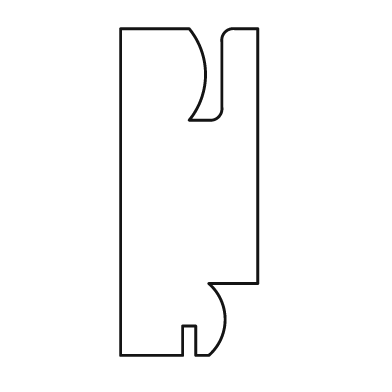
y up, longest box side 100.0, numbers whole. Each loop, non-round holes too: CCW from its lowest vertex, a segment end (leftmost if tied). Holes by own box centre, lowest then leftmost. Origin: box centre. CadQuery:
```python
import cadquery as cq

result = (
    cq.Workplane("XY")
    .moveTo(-21.0, -50.0)
    .lineTo(-2.0, -50.0)
    .lineTo(-2.0, -41.0)
    .lineTo(2.0, -41.0)
    .lineTo(2.0, -50.0)
    .lineTo(6.0, -50.0)
    .threePointArc((11.0, -39.0), (6.0, -28.0))
    .lineTo(21.0, -28.0)
    .lineTo(21.0, 50.0)
    .lineTo(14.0, 50.0)
    .threePointArc((11.0, 49.0), (10.0, 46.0))
    .lineTo(10.0, 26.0)
    .threePointArc((9.0, 23.0), (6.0, 22.0))
    .lineTo(0.0, 22.0)
    .threePointArc((5.0, 36.0), (0.0, 50.0))
    .lineTo(-21.0, 50.0)
    .close()
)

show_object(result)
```